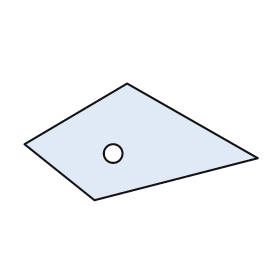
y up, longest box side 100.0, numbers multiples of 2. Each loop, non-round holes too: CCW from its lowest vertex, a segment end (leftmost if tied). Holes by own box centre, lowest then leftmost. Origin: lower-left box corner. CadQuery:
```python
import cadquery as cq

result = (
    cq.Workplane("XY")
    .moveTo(30.0, 0.0)
    .lineTo(100.0, 18.0)
    .lineTo(44.0, 50.0)
    .lineTo(0.0, 24.0)
    .close()
    .moveTo(38.0, 20.0)
    .circle(4.0)
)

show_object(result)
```